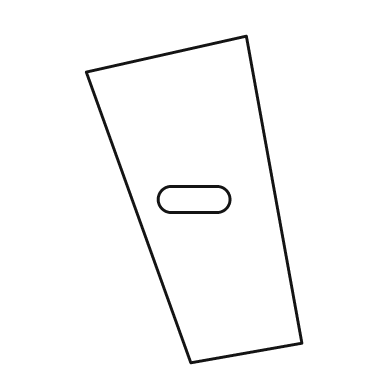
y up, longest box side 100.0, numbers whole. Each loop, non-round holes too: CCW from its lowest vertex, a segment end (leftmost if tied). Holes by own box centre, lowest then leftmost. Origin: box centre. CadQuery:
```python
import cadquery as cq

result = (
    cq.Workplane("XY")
    .moveTo(-1.0, -50.0)
    .lineTo(33.0, -44.0)
    .lineTo(16.0, 50.0)
    .lineTo(-33.0, 39.0)
    .close()
    .moveTo(-7.0, -4.0)
    .lineTo(7.0, -4.0)
    .threePointArc((11.0, 0.0), (7.0, 4.0))
    .lineTo(-7.0, 4.0)
    .threePointArc((-11.0, 0.0), (-7.0, -4.0))
    .close()
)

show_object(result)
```